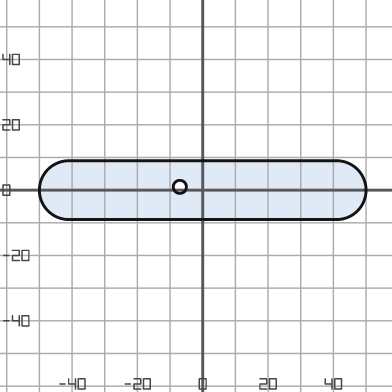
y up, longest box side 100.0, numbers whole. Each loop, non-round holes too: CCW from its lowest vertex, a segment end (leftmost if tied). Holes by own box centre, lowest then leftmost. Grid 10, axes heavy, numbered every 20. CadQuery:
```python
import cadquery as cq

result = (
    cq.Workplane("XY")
    .moveTo(-41.0, -9.0)
    .lineTo(41.0, -9.0)
    .threePointArc((50.0, 0.0), (41.0, 9.0))
    .lineTo(-41.0, 9.0)
    .threePointArc((-50.0, 0.0), (-41.0, -9.0))
    .close()
    .moveTo(-7.0, 1.0)
    .circle(2.0)
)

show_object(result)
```